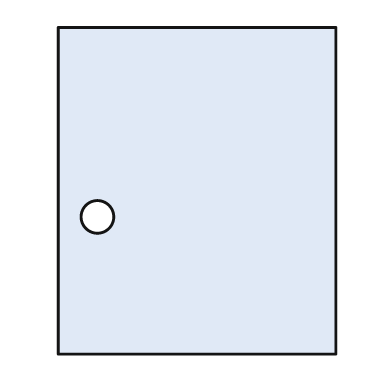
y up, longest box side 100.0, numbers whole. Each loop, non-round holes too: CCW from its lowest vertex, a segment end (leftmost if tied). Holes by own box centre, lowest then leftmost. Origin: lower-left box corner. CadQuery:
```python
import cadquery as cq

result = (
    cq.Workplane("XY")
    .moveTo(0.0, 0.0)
    .lineTo(85.0, 0.0)
    .lineTo(85.0, 100.0)
    .lineTo(0.0, 100.0)
    .close()
    .moveTo(12.0, 42.0)
    .circle(5.0)
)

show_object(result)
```